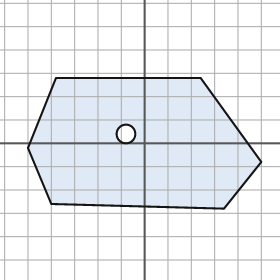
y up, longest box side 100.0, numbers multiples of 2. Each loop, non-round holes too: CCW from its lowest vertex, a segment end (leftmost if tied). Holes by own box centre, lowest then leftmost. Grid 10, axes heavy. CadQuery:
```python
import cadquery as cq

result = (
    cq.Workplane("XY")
    .moveTo(34.0, -28.0)
    .lineTo(50.0, -8.0)
    .lineTo(24.0, 28.0)
    .lineTo(-38.0, 28.0)
    .lineTo(-50.0, -2.0)
    .lineTo(-40.0, -26.0)
    .close()
    .moveTo(-8.0, 4.0)
    .circle(4.0)
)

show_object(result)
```